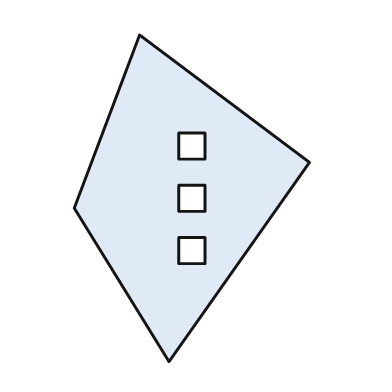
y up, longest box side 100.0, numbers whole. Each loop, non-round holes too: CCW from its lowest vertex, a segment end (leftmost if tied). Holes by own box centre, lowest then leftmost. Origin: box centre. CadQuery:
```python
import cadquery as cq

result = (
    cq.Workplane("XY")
    .moveTo(-7.0, -50.0)
    .lineTo(36.0, 11.0)
    .lineTo(-16.0, 50.0)
    .lineTo(-36.0, -3.0)
    .close()
    .moveTo(-4.0, -20.0)
    .lineTo(4.0, -20.0)
    .lineTo(4.0, -12.0)
    .lineTo(-4.0, -12.0)
    .close()
    .moveTo(-4.0, -4.0)
    .lineTo(4.0, -4.0)
    .lineTo(4.0, 4.0)
    .lineTo(-4.0, 4.0)
    .close()
    .moveTo(-4.0, 12.0)
    .lineTo(4.0, 12.0)
    .lineTo(4.0, 20.0)
    .lineTo(-4.0, 20.0)
    .close()
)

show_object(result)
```